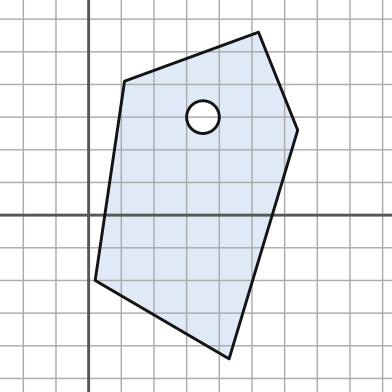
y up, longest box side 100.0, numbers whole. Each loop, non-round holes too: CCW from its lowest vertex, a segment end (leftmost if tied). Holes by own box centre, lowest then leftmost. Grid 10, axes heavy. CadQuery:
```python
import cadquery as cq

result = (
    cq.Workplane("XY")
    .moveTo(43.0, -44.0)
    .lineTo(64.0, 26.0)
    .lineTo(52.0, 56.0)
    .lineTo(11.0, 41.0)
    .lineTo(2.0, -20.0)
    .close()
    .moveTo(35.0, 30.0)
    .circle(5.0)
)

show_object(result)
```